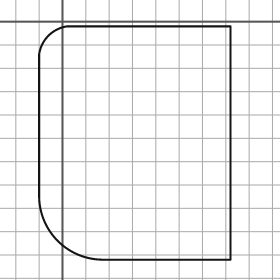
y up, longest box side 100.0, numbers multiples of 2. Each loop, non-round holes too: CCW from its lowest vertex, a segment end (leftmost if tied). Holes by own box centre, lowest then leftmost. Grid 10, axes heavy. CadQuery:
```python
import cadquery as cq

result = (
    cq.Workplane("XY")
    .moveTo(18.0, -102.0)
    .lineTo(72.0, -102.0)
    .lineTo(72.0, -2.0)
    .lineTo(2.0, -2.0)
    .threePointArc((-6.0, -6.0), (-10.0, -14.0))
    .lineTo(-10.0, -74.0)
    .threePointArc((-2.0, -94.0), (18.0, -102.0))
    .close()
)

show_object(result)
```